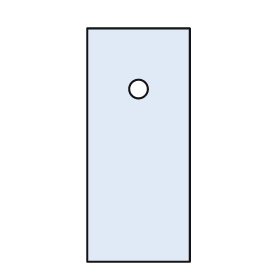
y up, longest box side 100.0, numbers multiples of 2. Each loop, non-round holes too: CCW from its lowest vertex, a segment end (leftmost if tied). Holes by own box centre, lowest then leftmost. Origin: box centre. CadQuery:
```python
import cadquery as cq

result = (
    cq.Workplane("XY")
    .moveTo(-22.0, -50.0)
    .lineTo(22.0, -50.0)
    .lineTo(22.0, 50.0)
    .lineTo(-22.0, 50.0)
    .close()
    .moveTo(0.0, 24.0)
    .circle(4.0)
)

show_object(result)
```